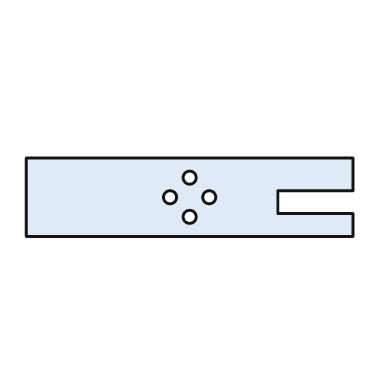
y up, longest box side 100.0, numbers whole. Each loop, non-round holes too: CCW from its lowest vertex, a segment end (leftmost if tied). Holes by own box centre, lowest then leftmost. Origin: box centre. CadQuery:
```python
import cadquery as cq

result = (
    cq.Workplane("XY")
    .moveTo(-50.0, -12.0)
    .lineTo(50.0, -12.0)
    .lineTo(50.0, -5.0)
    .lineTo(27.0, -5.0)
    .lineTo(27.0, 2.0)
    .lineTo(50.0, 2.0)
    .lineTo(50.0, 12.0)
    .lineTo(-50.0, 12.0)
    .close()
    .moveTo(0.0, -6.0)
    .circle(2.0)
    .moveTo(-6.0, 0.0)
    .circle(2.0)
    .moveTo(6.0, 0.0)
    .circle(2.0)
    .moveTo(0.0, 6.0)
    .circle(2.0)
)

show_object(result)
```